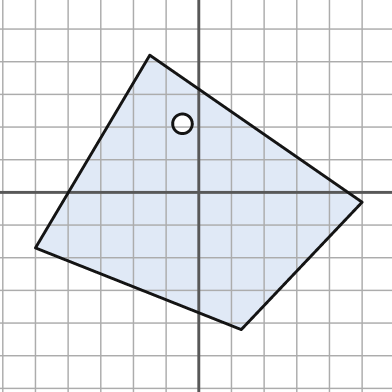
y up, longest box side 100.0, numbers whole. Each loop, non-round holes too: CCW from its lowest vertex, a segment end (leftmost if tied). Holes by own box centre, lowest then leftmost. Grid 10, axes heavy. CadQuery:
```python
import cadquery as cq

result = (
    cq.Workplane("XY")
    .moveTo(13.0, -42.0)
    .lineTo(50.0, -3.0)
    .lineTo(-15.0, 42.0)
    .lineTo(-50.0, -17.0)
    .close()
    .moveTo(-5.0, 21.0)
    .circle(3.0)
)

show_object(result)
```